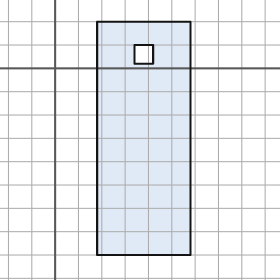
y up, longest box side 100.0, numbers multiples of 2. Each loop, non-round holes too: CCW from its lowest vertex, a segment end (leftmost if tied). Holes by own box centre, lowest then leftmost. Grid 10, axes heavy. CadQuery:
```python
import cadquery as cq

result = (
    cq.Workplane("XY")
    .moveTo(18.0, -80.0)
    .lineTo(58.0, -80.0)
    .lineTo(58.0, 20.0)
    .lineTo(18.0, 20.0)
    .close()
    .moveTo(34.0, 2.0)
    .lineTo(42.0, 2.0)
    .lineTo(42.0, 10.0)
    .lineTo(34.0, 10.0)
    .close()
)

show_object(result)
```